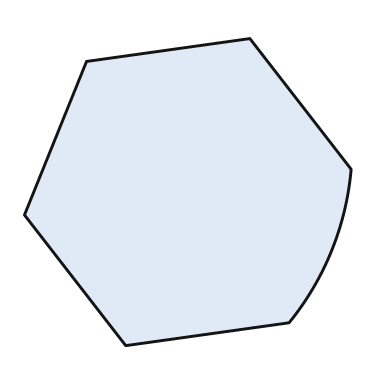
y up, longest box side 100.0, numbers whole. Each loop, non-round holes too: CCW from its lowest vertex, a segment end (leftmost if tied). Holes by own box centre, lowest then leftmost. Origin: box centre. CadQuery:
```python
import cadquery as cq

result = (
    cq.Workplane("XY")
    .moveTo(-19.0, -47.0)
    .lineTo(31.0, -40.0)
    .threePointArc((44.0, -18.0), (50.0, 7.0))
    .lineTo(19.0, 47.0)
    .lineTo(-31.0, 40.0)
    .lineTo(-50.0, -7.0)
    .close()
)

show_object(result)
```